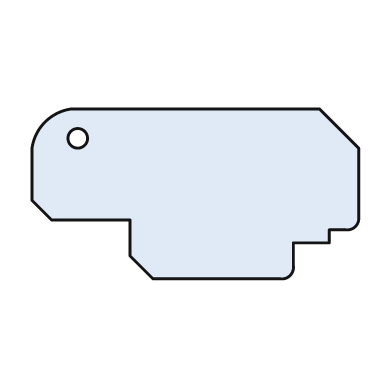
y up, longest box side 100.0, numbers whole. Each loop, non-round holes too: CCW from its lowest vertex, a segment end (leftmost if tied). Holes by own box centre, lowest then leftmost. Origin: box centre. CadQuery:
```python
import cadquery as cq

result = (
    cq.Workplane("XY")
    .moveTo(-13.0, -26.0)
    .lineTo(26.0, -26.0)
    .threePointArc((29.0, -25.0), (30.0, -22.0))
    .lineTo(30.0, -15.0)
    .lineTo(41.0, -15.0)
    .lineTo(41.0, -11.0)
    .lineTo(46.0, -11.0)
    .threePointArc((49.0, -10.0), (50.0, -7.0))
    .lineTo(50.0, 14.0)
    .lineTo(38.0, 26.0)
    .lineTo(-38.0, 26.0)
    .threePointArc((-46.0, 22.0), (-50.0, 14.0))
    .lineTo(-50.0, -2.0)
    .lineTo(-44.0, -8.0)
    .lineTo(-20.0, -8.0)
    .lineTo(-20.0, -19.0)
    .close()
    .moveTo(-36.0, 17.0)
    .circle(3.0)
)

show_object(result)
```